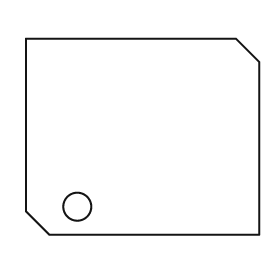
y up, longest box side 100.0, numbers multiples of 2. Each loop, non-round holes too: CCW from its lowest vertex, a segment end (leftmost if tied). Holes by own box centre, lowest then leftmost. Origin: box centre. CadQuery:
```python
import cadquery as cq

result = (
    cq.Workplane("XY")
    .moveTo(-40.0, -42.0)
    .lineTo(50.0, -42.0)
    .lineTo(50.0, 32.0)
    .lineTo(40.0, 42.0)
    .lineTo(-50.0, 42.0)
    .lineTo(-50.0, -32.0)
    .close()
    .moveTo(-28.0, -30.0)
    .circle(6.0)
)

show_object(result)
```